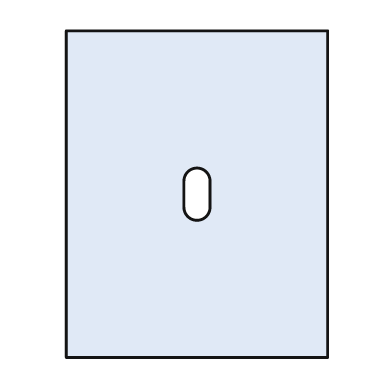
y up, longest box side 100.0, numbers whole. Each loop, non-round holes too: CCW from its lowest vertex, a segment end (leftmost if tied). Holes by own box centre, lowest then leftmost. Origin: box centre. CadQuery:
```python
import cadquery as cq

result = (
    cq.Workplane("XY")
    .moveTo(-40.0, -50.0)
    .lineTo(40.0, -50.0)
    .lineTo(40.0, 50.0)
    .lineTo(-40.0, 50.0)
    .close()
    .moveTo(-4.0, -4.0)
    .threePointArc((0.0, -8.0), (4.0, -4.0))
    .lineTo(4.0, 4.0)
    .threePointArc((0.0, 8.0), (-4.0, 4.0))
    .close()
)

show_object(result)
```